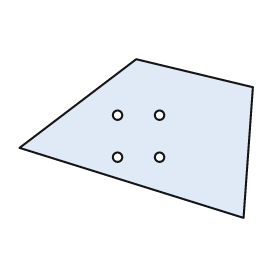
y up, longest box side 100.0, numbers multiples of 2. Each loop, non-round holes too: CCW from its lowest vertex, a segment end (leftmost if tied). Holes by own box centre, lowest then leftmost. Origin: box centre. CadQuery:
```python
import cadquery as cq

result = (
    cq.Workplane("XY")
    .moveTo(46.0, -34.0)
    .lineTo(50.0, 22.0)
    .lineTo(0.0, 34.0)
    .lineTo(-50.0, -4.0)
    .close()
    .moveTo(-8.0, -8.0)
    .circle(2.0)
    .moveTo(10.0, -8.0)
    .circle(2.0)
    .moveTo(-8.0, 10.0)
    .circle(2.0)
    .moveTo(10.0, 10.0)
    .circle(2.0)
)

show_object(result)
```